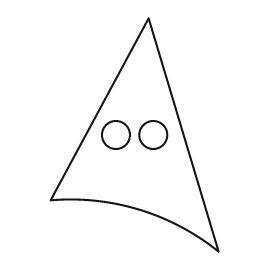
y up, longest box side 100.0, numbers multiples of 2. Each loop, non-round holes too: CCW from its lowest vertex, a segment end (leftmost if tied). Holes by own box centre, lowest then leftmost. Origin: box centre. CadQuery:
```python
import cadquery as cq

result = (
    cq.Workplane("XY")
    .moveTo(36.0, -50.0)
    .lineTo(6.0, 50.0)
    .lineTo(-36.0, -28.0)
    .threePointArc((2.0, -32.0), (36.0, -50.0))
    .close()
    .moveTo(-8.0, 0.0)
    .circle(6.0)
    .moveTo(8.0, 0.0)
    .circle(6.0)
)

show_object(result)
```